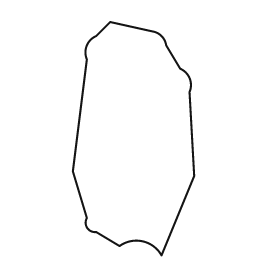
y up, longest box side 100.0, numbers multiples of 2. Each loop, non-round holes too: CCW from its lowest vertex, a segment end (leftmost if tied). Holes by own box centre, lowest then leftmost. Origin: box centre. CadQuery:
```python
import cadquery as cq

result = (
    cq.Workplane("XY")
    .moveTo(12.0, -50.0)
    .lineTo(26.0, -16.0)
    .lineTo(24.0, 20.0)
    .threePointArc((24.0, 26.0), (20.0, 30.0))
    .lineTo(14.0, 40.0)
    .threePointArc((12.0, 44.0), (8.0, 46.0))
    .lineTo(-10.0, 50.0)
    .lineTo(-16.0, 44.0)
    .threePointArc((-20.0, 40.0), (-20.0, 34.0))
    .lineTo(-26.0, -14.0)
    .lineTo(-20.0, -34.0)
    .threePointArc((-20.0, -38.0), (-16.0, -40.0))
    .lineTo(-6.0, -46.0)
    .threePointArc((4.0, -44.0), (12.0, -50.0))
    .close()
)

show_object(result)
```